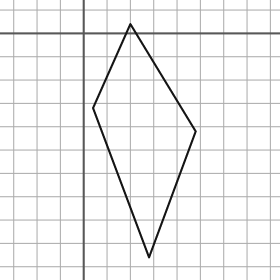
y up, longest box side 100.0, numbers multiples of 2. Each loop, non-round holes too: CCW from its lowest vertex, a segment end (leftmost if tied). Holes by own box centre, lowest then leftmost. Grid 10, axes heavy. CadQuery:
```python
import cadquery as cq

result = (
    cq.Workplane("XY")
    .moveTo(28.0, -96.0)
    .lineTo(48.0, -42.0)
    .lineTo(20.0, 4.0)
    .lineTo(4.0, -32.0)
    .close()
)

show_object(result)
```